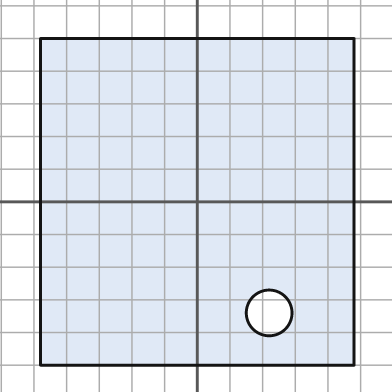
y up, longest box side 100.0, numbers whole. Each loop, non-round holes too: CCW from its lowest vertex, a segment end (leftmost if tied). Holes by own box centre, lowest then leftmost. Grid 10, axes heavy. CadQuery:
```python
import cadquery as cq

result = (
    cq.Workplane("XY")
    .moveTo(-48.0, -50.0)
    .lineTo(48.0, -50.0)
    .lineTo(48.0, 50.0)
    .lineTo(-48.0, 50.0)
    .close()
    .moveTo(22.0, -34.0)
    .circle(7.0)
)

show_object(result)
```